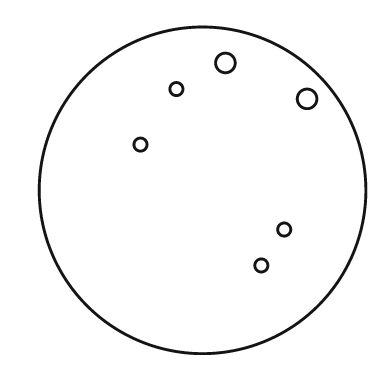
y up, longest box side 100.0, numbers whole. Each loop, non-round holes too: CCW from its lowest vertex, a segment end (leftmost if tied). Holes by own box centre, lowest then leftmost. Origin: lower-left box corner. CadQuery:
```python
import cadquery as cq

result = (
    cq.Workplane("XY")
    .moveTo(50.0, 50.0)
    .circle(50.0)
    .moveTo(68.0, 27.0)
    .circle(2.0)
    .moveTo(75.0, 38.0)
    .circle(2.0)
    .moveTo(31.0, 64.0)
    .circle(2.0)
    .moveTo(82.0, 78.0)
    .circle(3.0)
    .moveTo(42.0, 81.0)
    .circle(2.0)
    .moveTo(57.0, 89.0)
    .circle(3.0)
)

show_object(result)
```